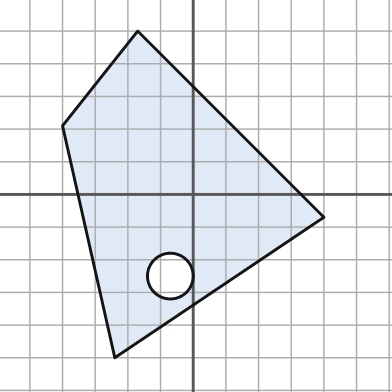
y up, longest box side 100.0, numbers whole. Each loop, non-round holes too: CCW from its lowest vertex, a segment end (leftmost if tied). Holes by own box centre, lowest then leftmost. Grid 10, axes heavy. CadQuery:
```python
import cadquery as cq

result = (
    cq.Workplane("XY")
    .moveTo(-24.0, -50.0)
    .lineTo(40.0, -7.0)
    .lineTo(-17.0, 50.0)
    .lineTo(-40.0, 21.0)
    .close()
    .moveTo(-7.0, -25.0)
    .circle(7.0)
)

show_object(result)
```